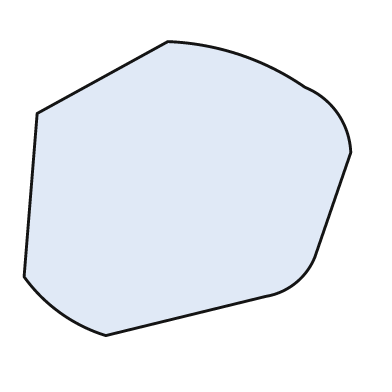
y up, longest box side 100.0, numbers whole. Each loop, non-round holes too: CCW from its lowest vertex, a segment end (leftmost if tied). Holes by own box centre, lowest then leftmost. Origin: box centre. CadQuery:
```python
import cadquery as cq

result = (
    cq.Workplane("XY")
    .moveTo(-25.0, -45.0)
    .lineTo(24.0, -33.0)
    .threePointArc((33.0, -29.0), (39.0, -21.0))
    .lineTo(50.0, 11.0)
    .threePointArc((46.0, 23.0), (36.0, 31.0))
    .threePointArc((16.0, 41.0), (-6.0, 45.0))
    .lineTo(-46.0, 23.0)
    .lineTo(-50.0, -27.0)
    .threePointArc((-39.0, -38.0), (-25.0, -45.0))
    .close()
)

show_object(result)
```